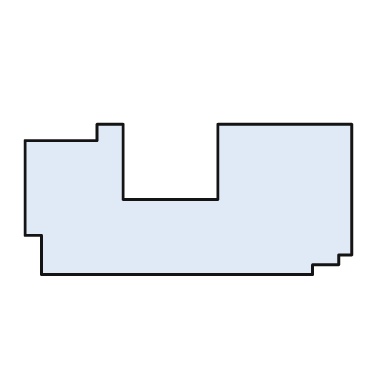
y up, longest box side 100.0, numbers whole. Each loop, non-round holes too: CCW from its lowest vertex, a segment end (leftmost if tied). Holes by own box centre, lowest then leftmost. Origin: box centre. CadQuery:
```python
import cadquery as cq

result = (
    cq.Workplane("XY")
    .moveTo(-45.0, -23.0)
    .lineTo(38.0, -23.0)
    .lineTo(38.0, -20.0)
    .lineTo(46.0, -20.0)
    .lineTo(46.0, -17.0)
    .lineTo(50.0, -17.0)
    .lineTo(50.0, 23.0)
    .lineTo(9.0, 23.0)
    .lineTo(9.0, 0.0)
    .lineTo(-20.0, 0.0)
    .lineTo(-20.0, 23.0)
    .lineTo(-28.0, 23.0)
    .lineTo(-28.0, 18.0)
    .lineTo(-50.0, 18.0)
    .lineTo(-50.0, -11.0)
    .lineTo(-45.0, -11.0)
    .close()
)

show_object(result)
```